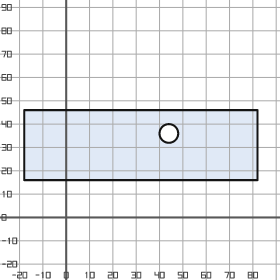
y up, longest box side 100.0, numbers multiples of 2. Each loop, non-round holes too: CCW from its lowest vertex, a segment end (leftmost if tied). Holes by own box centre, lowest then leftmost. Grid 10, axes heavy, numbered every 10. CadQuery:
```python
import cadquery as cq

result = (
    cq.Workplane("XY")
    .moveTo(-18.0, 16.0)
    .lineTo(82.0, 16.0)
    .lineTo(82.0, 46.0)
    .lineTo(-18.0, 46.0)
    .close()
    .moveTo(44.0, 36.0)
    .circle(4.0)
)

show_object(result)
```